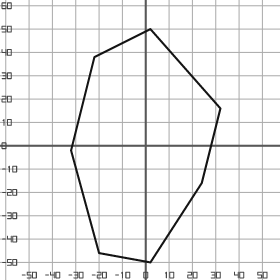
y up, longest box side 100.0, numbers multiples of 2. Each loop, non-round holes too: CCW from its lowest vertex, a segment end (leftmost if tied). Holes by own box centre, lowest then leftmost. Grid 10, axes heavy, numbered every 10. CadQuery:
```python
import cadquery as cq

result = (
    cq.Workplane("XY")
    .moveTo(2.0, -50.0)
    .lineTo(24.0, -16.0)
    .lineTo(32.0, 16.0)
    .lineTo(2.0, 50.0)
    .lineTo(-22.0, 38.0)
    .lineTo(-32.0, -2.0)
    .lineTo(-20.0, -46.0)
    .close()
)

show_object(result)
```